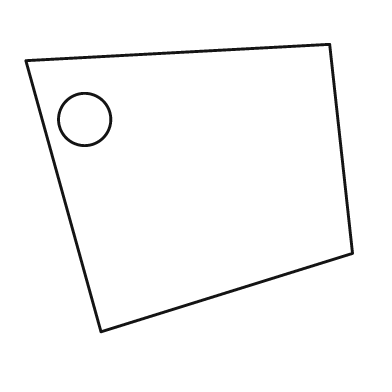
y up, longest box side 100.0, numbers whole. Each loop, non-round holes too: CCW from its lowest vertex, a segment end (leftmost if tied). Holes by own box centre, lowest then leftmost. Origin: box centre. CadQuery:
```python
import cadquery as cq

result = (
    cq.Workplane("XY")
    .moveTo(-27.0, -44.0)
    .lineTo(50.0, -20.0)
    .lineTo(43.0, 44.0)
    .lineTo(-50.0, 39.0)
    .close()
    .moveTo(-32.0, 21.0)
    .circle(8.0)
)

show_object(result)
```